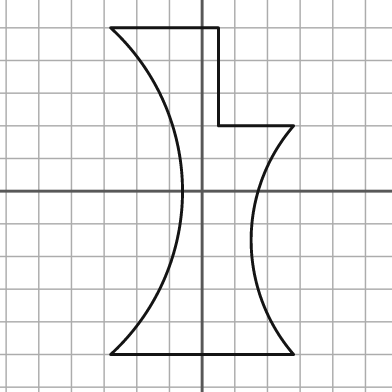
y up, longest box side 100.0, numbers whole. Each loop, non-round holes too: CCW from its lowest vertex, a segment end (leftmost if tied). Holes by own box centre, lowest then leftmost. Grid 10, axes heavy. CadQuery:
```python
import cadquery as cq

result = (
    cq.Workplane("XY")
    .moveTo(-28.0, -50.0)
    .lineTo(28.0, -50.0)
    .threePointArc((15.0, -15.0), (28.0, 20.0))
    .lineTo(5.0, 20.0)
    .lineTo(5.0, 50.0)
    .lineTo(-28.0, 50.0)
    .threePointArc((-6.0, 0.0), (-28.0, -50.0))
    .close()
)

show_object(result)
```